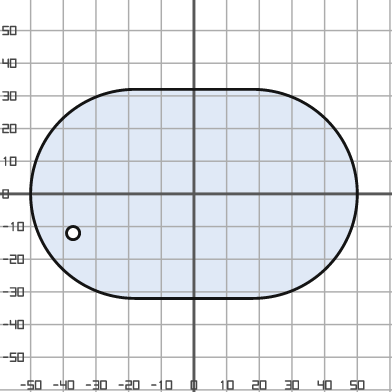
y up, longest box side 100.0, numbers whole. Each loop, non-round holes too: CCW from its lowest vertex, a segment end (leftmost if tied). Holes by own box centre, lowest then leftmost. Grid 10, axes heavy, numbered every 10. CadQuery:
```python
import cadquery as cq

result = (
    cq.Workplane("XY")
    .moveTo(-18.0, -32.0)
    .lineTo(18.0, -32.0)
    .threePointArc((50.0, 0.0), (18.0, 32.0))
    .lineTo(-18.0, 32.0)
    .threePointArc((-50.0, 0.0), (-18.0, -32.0))
    .close()
    .moveTo(-37.0, -12.0)
    .circle(2.0)
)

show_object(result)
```